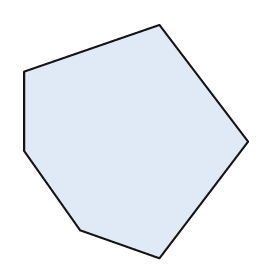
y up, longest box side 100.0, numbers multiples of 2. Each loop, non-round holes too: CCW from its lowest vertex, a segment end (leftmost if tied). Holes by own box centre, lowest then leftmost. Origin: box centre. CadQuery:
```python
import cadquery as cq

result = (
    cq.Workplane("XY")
    .moveTo(10.0, -50.0)
    .lineTo(48.0, 0.0)
    .lineTo(10.0, 50.0)
    .lineTo(-48.0, 30.0)
    .lineTo(-48.0, -4.0)
    .lineTo(-24.0, -38.0)
    .close()
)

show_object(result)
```